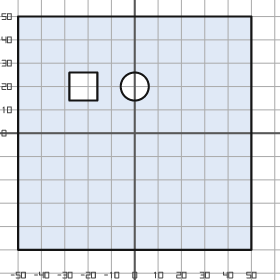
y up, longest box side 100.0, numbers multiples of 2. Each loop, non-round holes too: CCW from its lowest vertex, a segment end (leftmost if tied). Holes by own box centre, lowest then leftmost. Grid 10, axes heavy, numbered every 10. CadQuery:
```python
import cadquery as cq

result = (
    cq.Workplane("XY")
    .moveTo(-50.0, -50.0)
    .lineTo(50.0, -50.0)
    .lineTo(50.0, 50.0)
    .lineTo(-50.0, 50.0)
    .close()
    .moveTo(-28.0, 14.0)
    .lineTo(-16.0, 14.0)
    .lineTo(-16.0, 26.0)
    .lineTo(-28.0, 26.0)
    .close()
    .moveTo(0.0, 20.0)
    .circle(6.0)
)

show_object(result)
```